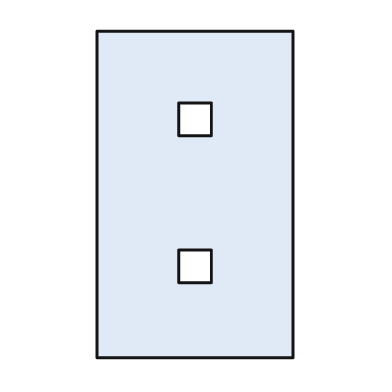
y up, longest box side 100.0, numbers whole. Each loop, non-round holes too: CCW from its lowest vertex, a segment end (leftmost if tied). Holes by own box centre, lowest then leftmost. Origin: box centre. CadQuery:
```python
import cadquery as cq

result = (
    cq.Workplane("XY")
    .moveTo(-30.0, -50.0)
    .lineTo(30.0, -50.0)
    .lineTo(30.0, 50.0)
    .lineTo(-30.0, 50.0)
    .close()
    .moveTo(-5.0, -27.0)
    .lineTo(5.0, -27.0)
    .lineTo(5.0, -17.0)
    .lineTo(-5.0, -17.0)
    .close()
    .moveTo(-5.0, 18.0)
    .lineTo(5.0, 18.0)
    .lineTo(5.0, 28.0)
    .lineTo(-5.0, 28.0)
    .close()
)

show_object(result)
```